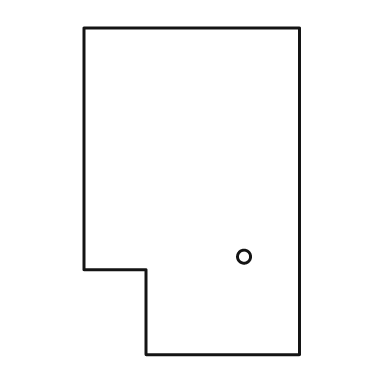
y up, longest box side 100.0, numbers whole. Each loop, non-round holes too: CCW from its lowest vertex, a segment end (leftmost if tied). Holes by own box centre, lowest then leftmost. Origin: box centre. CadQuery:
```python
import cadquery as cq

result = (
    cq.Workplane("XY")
    .moveTo(-14.0, -50.0)
    .lineTo(33.0, -50.0)
    .lineTo(33.0, 50.0)
    .lineTo(-33.0, 50.0)
    .lineTo(-33.0, -24.0)
    .lineTo(-14.0, -24.0)
    .close()
    .moveTo(16.0, -20.0)
    .circle(2.0)
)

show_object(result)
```